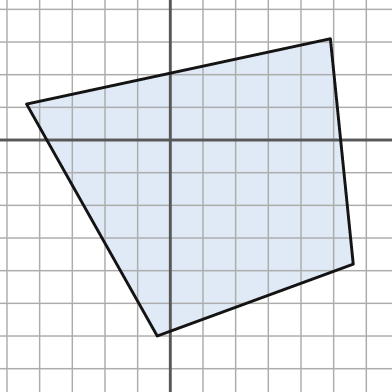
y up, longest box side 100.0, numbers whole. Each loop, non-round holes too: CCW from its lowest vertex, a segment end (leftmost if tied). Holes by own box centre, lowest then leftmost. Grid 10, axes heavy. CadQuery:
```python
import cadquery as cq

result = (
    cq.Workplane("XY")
    .moveTo(-4.0, -60.0)
    .lineTo(56.0, -38.0)
    .lineTo(49.0, 31.0)
    .lineTo(-44.0, 11.0)
    .close()
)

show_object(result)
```